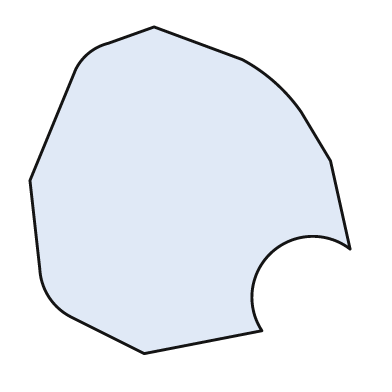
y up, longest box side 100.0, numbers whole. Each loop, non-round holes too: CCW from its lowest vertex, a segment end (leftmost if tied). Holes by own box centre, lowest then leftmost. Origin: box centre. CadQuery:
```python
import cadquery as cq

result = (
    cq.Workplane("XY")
    .moveTo(-14.0, -50.0)
    .lineTo(22.0, -43.0)
    .threePointArc((25.0, -19.0), (49.0, -18.0))
    .lineTo(43.0, 9.0)
    .lineTo(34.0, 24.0)
    .threePointArc((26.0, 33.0), (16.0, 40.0))
    .lineTo(-11.0, 50.0)
    .lineTo(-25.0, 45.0)
    .threePointArc((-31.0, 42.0), (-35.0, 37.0))
    .lineTo(-49.0, 3.0)
    .lineTo(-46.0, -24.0)
    .threePointArc((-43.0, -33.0), (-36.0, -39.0))
    .close()
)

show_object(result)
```